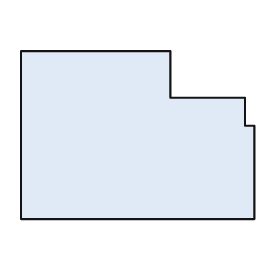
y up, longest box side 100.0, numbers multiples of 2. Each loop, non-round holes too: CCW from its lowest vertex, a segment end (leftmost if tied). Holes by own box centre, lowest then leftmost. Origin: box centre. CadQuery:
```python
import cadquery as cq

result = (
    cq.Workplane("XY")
    .moveTo(-50.0, -36.0)
    .lineTo(50.0, -36.0)
    .lineTo(50.0, 4.0)
    .lineTo(46.0, 4.0)
    .lineTo(46.0, 16.0)
    .lineTo(14.0, 16.0)
    .lineTo(14.0, 36.0)
    .lineTo(-50.0, 36.0)
    .close()
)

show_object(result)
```